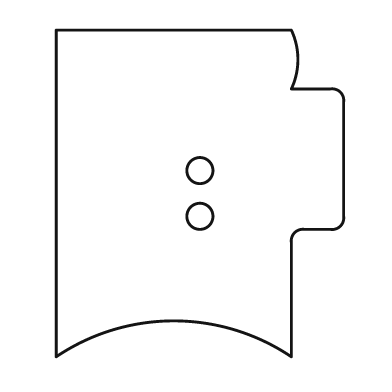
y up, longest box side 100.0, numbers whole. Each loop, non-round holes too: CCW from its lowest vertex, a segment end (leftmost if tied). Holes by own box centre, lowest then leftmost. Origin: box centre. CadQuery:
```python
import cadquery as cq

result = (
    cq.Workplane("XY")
    .moveTo(-44.0, -50.0)
    .threePointArc((-8.0, -39.0), (28.0, -50.0))
    .lineTo(28.0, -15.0)
    .threePointArc((29.0, -12.0), (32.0, -11.0))
    .lineTo(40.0, -11.0)
    .threePointArc((43.0, -10.0), (44.0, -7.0))
    .lineTo(44.0, 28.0)
    .threePointArc((43.0, 31.0), (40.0, 32.0))
    .lineTo(28.0, 32.0)
    .threePointArc((30.0, 41.0), (28.0, 50.0))
    .lineTo(-44.0, 50.0)
    .close()
    .moveTo(0.0, -7.0)
    .circle(4.0)
    .moveTo(0.0, 7.0)
    .circle(4.0)
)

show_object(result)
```